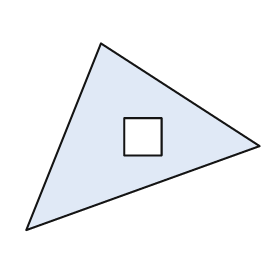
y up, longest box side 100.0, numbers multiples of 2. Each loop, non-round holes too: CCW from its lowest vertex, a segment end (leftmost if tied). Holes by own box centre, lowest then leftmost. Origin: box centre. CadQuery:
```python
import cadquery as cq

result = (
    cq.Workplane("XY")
    .moveTo(-50.0, -40.0)
    .lineTo(50.0, -4.0)
    .lineTo(-18.0, 40.0)
    .close()
    .moveTo(-8.0, -8.0)
    .lineTo(8.0, -8.0)
    .lineTo(8.0, 8.0)
    .lineTo(-8.0, 8.0)
    .close()
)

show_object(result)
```